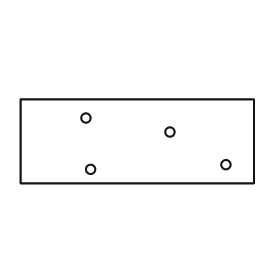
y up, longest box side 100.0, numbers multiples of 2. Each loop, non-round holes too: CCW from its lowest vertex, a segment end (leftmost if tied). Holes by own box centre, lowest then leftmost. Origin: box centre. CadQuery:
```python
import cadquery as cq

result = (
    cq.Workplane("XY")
    .moveTo(-50.0, -18.0)
    .lineTo(50.0, -18.0)
    .lineTo(50.0, 18.0)
    .lineTo(-50.0, 18.0)
    .close()
    .moveTo(-20.0, -12.0)
    .circle(2.0)
    .moveTo(38.0, -10.0)
    .circle(2.0)
    .moveTo(14.0, 4.0)
    .circle(2.0)
    .moveTo(-22.0, 10.0)
    .circle(2.0)
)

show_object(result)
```